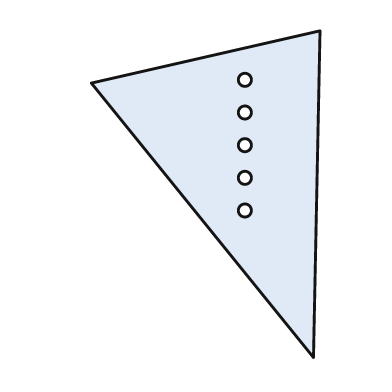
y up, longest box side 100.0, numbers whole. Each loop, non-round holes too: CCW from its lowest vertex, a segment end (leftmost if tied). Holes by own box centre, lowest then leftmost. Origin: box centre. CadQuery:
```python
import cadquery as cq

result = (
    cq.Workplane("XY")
    .moveTo(33.0, -50.0)
    .lineTo(35.0, 50.0)
    .lineTo(-35.0, 34.0)
    .close()
    .moveTo(12.0, -5.0)
    .circle(2.0)
    .moveTo(12.0, 5.0)
    .circle(2.0)
    .moveTo(12.0, 15.0)
    .circle(2.0)
    .moveTo(12.0, 25.0)
    .circle(2.0)
    .moveTo(12.0, 35.0)
    .circle(2.0)
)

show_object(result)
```